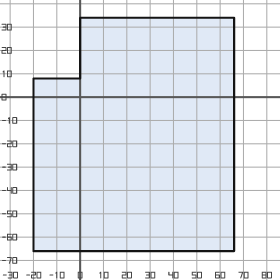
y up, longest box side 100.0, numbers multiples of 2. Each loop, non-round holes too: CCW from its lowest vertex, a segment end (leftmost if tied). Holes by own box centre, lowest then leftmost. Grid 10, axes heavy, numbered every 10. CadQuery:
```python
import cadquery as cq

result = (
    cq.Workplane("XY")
    .moveTo(-20.0, -66.0)
    .lineTo(66.0, -66.0)
    .lineTo(66.0, 34.0)
    .lineTo(0.0, 34.0)
    .lineTo(0.0, 8.0)
    .lineTo(-20.0, 8.0)
    .close()
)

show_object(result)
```